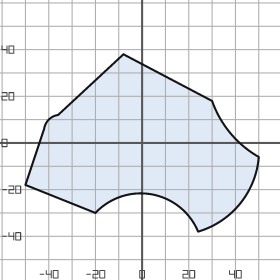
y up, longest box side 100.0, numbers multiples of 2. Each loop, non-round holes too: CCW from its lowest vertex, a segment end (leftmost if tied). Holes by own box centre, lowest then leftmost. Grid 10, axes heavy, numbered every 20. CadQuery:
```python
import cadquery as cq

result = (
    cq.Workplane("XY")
    .moveTo(24.0, -38.0)
    .threePointArc((42.0, -26.0), (50.0, -6.0))
    .threePointArc((38.0, 4.0), (30.0, 18.0))
    .lineTo(-8.0, 38.0)
    .lineTo(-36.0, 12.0)
    .threePointArc((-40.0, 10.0), (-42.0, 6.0))
    .lineTo(-50.0, -18.0)
    .lineTo(-20.0, -30.0)
    .threePointArc((4.0, -22.0), (24.0, -38.0))
    .close()
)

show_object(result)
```